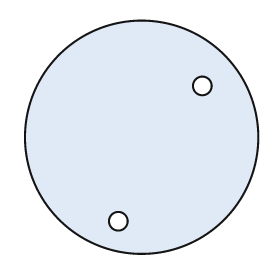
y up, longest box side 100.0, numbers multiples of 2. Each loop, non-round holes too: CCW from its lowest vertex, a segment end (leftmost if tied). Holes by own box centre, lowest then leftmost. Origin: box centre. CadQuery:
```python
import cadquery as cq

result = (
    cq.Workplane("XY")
    .moveTo(0.0, 0.0)
    .circle(50.0)
    .moveTo(-10.0, -36.0)
    .circle(4.0)
    .moveTo(26.0, 22.0)
    .circle(4.0)
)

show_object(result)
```